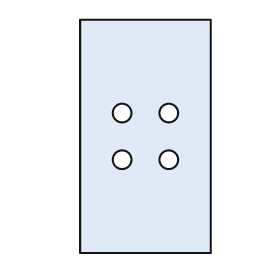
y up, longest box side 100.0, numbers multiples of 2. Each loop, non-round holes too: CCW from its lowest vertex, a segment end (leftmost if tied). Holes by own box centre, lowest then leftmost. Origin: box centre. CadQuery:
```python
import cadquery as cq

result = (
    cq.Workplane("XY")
    .moveTo(-28.0, -50.0)
    .lineTo(28.0, -50.0)
    .lineTo(28.0, 50.0)
    .lineTo(-28.0, 50.0)
    .close()
    .moveTo(-10.0, -10.0)
    .circle(4.0)
    .moveTo(10.0, -10.0)
    .circle(4.0)
    .moveTo(-10.0, 10.0)
    .circle(4.0)
    .moveTo(10.0, 10.0)
    .circle(4.0)
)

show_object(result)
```